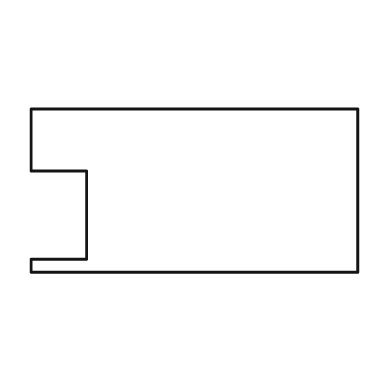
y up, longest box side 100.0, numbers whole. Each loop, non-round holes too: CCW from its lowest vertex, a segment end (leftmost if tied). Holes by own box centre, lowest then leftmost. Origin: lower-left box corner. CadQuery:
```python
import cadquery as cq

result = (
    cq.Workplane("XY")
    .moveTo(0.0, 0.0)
    .lineTo(100.0, 0.0)
    .lineTo(100.0, 50.0)
    .lineTo(0.0, 50.0)
    .lineTo(0.0, 31.0)
    .lineTo(17.0, 31.0)
    .lineTo(17.0, 4.0)
    .lineTo(0.0, 4.0)
    .close()
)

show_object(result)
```